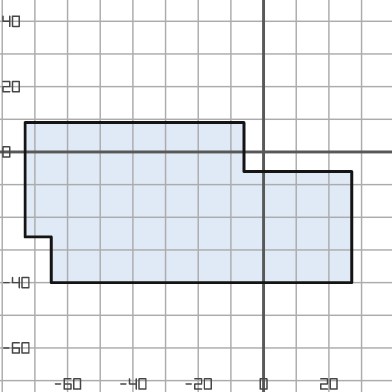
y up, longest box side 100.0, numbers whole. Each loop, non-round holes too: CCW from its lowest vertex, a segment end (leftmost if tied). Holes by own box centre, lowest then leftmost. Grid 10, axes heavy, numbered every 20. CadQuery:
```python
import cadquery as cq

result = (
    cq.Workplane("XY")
    .moveTo(-65.0, -40.0)
    .lineTo(27.0, -40.0)
    .lineTo(27.0, -6.0)
    .lineTo(-6.0, -6.0)
    .lineTo(-6.0, 9.0)
    .lineTo(-73.0, 9.0)
    .lineTo(-73.0, -26.0)
    .lineTo(-65.0, -26.0)
    .close()
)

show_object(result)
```